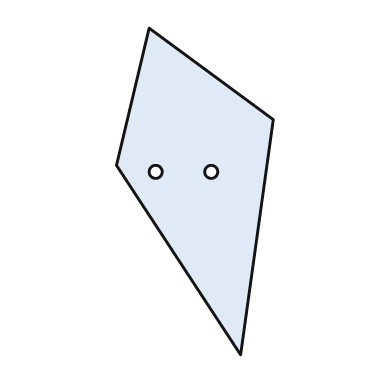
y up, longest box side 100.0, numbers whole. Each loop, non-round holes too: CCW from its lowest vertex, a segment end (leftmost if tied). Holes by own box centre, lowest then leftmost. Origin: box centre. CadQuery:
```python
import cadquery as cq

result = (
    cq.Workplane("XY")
    .moveTo(14.0, -50.0)
    .lineTo(24.0, 22.0)
    .lineTo(-14.0, 50.0)
    .lineTo(-24.0, 8.0)
    .close()
    .moveTo(-12.0, 6.0)
    .circle(2.0)
    .moveTo(5.0, 6.0)
    .circle(2.0)
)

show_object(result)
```